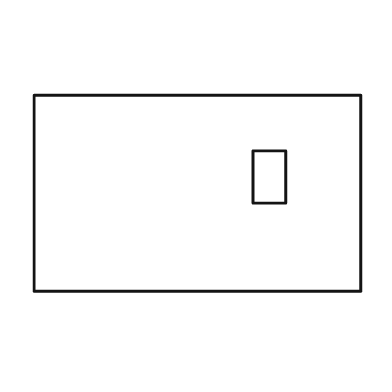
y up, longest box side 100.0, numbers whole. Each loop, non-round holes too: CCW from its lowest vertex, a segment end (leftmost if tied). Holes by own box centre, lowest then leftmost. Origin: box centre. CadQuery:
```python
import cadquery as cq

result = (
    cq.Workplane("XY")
    .moveTo(-50.0, -30.0)
    .lineTo(50.0, -30.0)
    .lineTo(50.0, 30.0)
    .lineTo(-50.0, 30.0)
    .close()
    .moveTo(17.0, -3.0)
    .lineTo(27.0, -3.0)
    .lineTo(27.0, 13.0)
    .lineTo(17.0, 13.0)
    .close()
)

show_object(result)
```